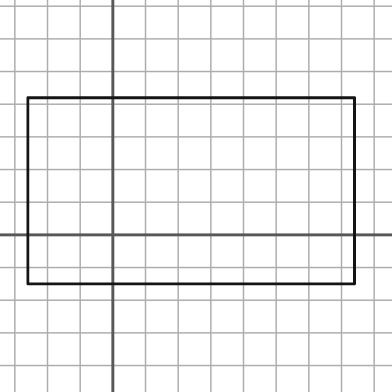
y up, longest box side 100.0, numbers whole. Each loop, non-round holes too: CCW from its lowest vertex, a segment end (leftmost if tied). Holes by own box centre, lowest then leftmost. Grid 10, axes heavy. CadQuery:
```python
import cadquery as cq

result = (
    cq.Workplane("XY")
    .moveTo(-26.0, -15.0)
    .lineTo(74.0, -15.0)
    .lineTo(74.0, 42.0)
    .lineTo(-26.0, 42.0)
    .close()
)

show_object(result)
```